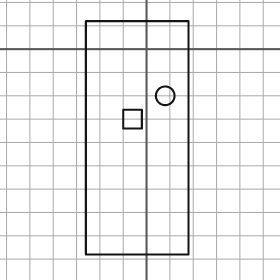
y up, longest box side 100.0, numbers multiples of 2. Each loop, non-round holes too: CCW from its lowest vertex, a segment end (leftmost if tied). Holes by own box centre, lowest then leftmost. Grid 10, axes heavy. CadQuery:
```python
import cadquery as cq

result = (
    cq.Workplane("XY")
    .moveTo(-26.0, -88.0)
    .lineTo(18.0, -88.0)
    .lineTo(18.0, 12.0)
    .lineTo(-26.0, 12.0)
    .close()
    .moveTo(-10.0, -34.0)
    .lineTo(-2.0, -34.0)
    .lineTo(-2.0, -26.0)
    .lineTo(-10.0, -26.0)
    .close()
    .moveTo(8.0, -20.0)
    .circle(4.0)
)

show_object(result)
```